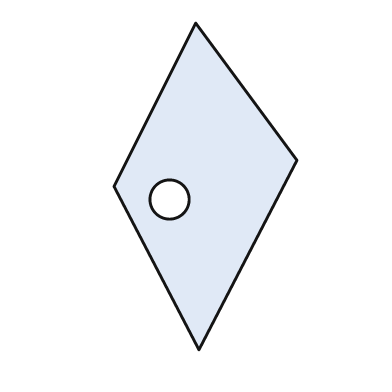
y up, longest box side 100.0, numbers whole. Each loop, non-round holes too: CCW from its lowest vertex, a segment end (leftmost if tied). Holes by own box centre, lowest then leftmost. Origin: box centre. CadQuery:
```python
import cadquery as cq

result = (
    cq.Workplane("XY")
    .moveTo(-2.0, -50.0)
    .lineTo(28.0, 8.0)
    .lineTo(-3.0, 50.0)
    .lineTo(-28.0, 0.0)
    .close()
    .moveTo(-11.0, -4.0)
    .circle(6.0)
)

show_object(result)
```